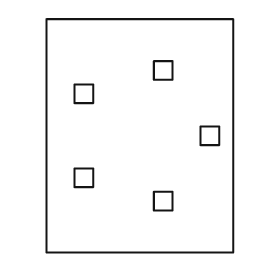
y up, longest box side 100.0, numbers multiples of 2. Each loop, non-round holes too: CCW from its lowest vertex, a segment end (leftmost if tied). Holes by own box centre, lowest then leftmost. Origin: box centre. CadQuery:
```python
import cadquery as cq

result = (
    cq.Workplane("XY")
    .moveTo(-40.0, -50.0)
    .lineTo(40.0, -50.0)
    .lineTo(40.0, 50.0)
    .lineTo(-40.0, 50.0)
    .close()
    .moveTo(6.0, -32.0)
    .lineTo(14.0, -32.0)
    .lineTo(14.0, -24.0)
    .lineTo(6.0, -24.0)
    .close()
    .moveTo(-28.0, -22.0)
    .lineTo(-20.0, -22.0)
    .lineTo(-20.0, -14.0)
    .lineTo(-28.0, -14.0)
    .close()
    .moveTo(26.0, -4.0)
    .lineTo(34.0, -4.0)
    .lineTo(34.0, 4.0)
    .lineTo(26.0, 4.0)
    .close()
    .moveTo(-28.0, 14.0)
    .lineTo(-20.0, 14.0)
    .lineTo(-20.0, 22.0)
    .lineTo(-28.0, 22.0)
    .close()
    .moveTo(6.0, 24.0)
    .lineTo(14.0, 24.0)
    .lineTo(14.0, 32.0)
    .lineTo(6.0, 32.0)
    .close()
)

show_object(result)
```